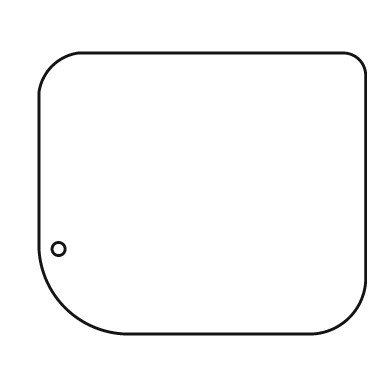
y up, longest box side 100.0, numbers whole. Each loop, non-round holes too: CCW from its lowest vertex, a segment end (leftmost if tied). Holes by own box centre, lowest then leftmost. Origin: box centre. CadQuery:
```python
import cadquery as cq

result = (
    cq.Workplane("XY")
    .moveTo(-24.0, -43.0)
    .lineTo(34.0, -43.0)
    .threePointArc((45.0, -38.0), (50.0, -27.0))
    .lineTo(50.0, 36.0)
    .threePointArc((48.0, 41.0), (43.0, 43.0))
    .lineTo(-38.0, 43.0)
    .threePointArc((-46.0, 39.0), (-50.0, 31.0))
    .lineTo(-50.0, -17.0)
    .threePointArc((-42.0, -35.0), (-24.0, -43.0))
    .close()
    .moveTo(-44.0, -17.0)
    .circle(2.0)
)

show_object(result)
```